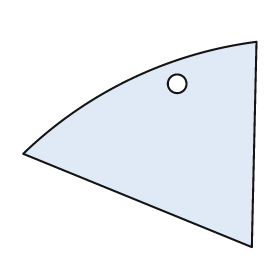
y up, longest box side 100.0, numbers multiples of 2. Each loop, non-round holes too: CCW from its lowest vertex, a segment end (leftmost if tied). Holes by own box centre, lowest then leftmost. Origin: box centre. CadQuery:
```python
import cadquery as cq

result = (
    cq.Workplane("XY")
    .moveTo(48.0, -44.0)
    .lineTo(50.0, 44.0)
    .threePointArc((-4.0, 28.0), (-50.0, -4.0))
    .close()
    .moveTo(16.0, 26.0)
    .circle(4.0)
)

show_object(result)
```